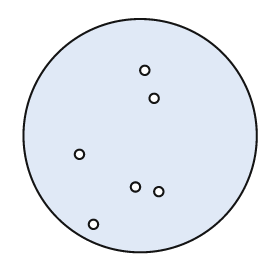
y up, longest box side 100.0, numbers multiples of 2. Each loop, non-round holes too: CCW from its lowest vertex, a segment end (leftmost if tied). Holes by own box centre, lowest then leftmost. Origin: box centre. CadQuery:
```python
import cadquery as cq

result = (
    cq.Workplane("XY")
    .moveTo(0.0, 0.0)
    .circle(50.0)
    .moveTo(-20.0, -38.0)
    .circle(2.0)
    .moveTo(8.0, -24.0)
    .circle(2.0)
    .moveTo(-2.0, -22.0)
    .circle(2.0)
    .moveTo(-26.0, -8.0)
    .circle(2.0)
    .moveTo(6.0, 16.0)
    .circle(2.0)
    .moveTo(2.0, 28.0)
    .circle(2.0)
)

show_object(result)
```